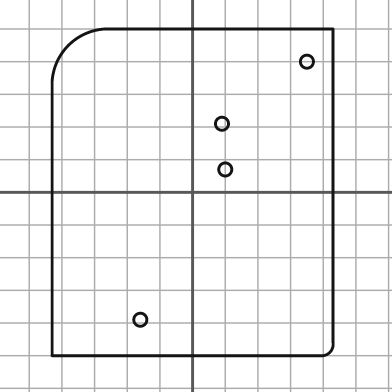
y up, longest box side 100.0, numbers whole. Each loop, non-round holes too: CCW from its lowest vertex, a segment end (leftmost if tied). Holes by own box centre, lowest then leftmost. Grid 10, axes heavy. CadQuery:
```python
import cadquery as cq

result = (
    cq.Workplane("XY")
    .moveTo(-43.0, -50.0)
    .lineTo(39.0, -50.0)
    .threePointArc((42.0, -49.0), (43.0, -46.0))
    .lineTo(43.0, 50.0)
    .lineTo(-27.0, 50.0)
    .threePointArc((-38.0, 45.0), (-43.0, 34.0))
    .close()
    .moveTo(-16.0, -39.0)
    .circle(2.0)
    .moveTo(10.0, 7.0)
    .circle(2.0)
    .moveTo(9.0, 21.0)
    .circle(2.0)
    .moveTo(35.0, 40.0)
    .circle(2.0)
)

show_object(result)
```